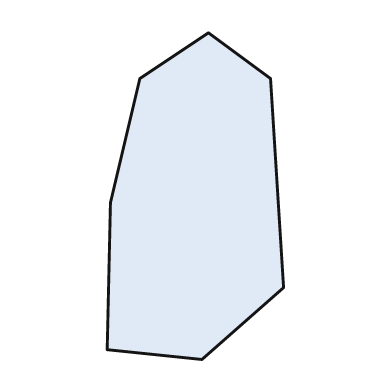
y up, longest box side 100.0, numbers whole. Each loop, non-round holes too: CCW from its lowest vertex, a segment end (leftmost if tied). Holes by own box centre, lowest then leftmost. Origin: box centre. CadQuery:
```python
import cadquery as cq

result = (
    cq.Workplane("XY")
    .moveTo(2.0, -50.0)
    .lineTo(27.0, -28.0)
    .lineTo(23.0, 36.0)
    .lineTo(4.0, 50.0)
    .lineTo(-17.0, 36.0)
    .lineTo(-26.0, -2.0)
    .lineTo(-27.0, -47.0)
    .close()
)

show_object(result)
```